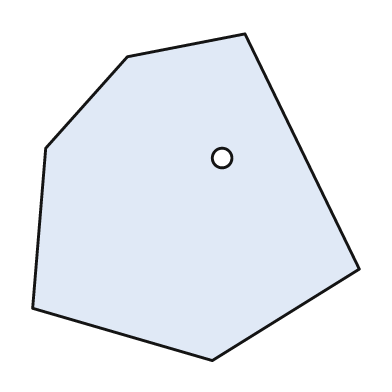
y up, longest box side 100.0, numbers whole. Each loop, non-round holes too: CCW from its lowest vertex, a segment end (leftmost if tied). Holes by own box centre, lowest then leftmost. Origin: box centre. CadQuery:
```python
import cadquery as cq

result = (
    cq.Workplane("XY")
    .moveTo(5.0, -50.0)
    .lineTo(50.0, -22.0)
    .lineTo(15.0, 50.0)
    .lineTo(-21.0, 43.0)
    .lineTo(-46.0, 15.0)
    .lineTo(-50.0, -34.0)
    .close()
    .moveTo(8.0, 12.0)
    .circle(3.0)
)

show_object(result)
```